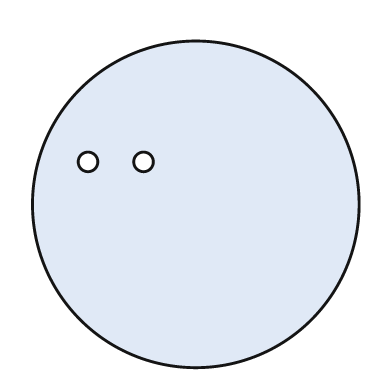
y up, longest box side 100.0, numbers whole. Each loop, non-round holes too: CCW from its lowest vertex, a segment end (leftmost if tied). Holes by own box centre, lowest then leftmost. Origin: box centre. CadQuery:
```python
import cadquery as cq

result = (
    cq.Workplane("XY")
    .moveTo(0.0, 0.0)
    .circle(50.0)
    .moveTo(-33.0, 13.0)
    .circle(3.0)
    .moveTo(-16.0, 13.0)
    .circle(3.0)
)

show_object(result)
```